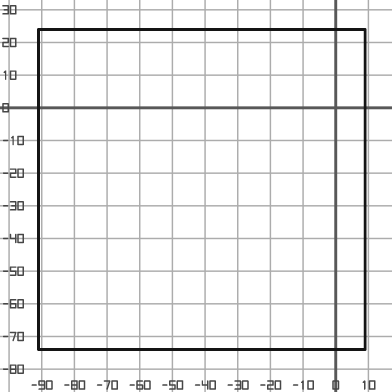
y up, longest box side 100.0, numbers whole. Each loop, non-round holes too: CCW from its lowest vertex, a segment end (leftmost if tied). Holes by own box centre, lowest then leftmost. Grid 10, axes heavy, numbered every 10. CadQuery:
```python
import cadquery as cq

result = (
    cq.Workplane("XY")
    .moveTo(-91.0, -74.0)
    .lineTo(9.0, -74.0)
    .lineTo(9.0, 24.0)
    .lineTo(-91.0, 24.0)
    .close()
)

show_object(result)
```